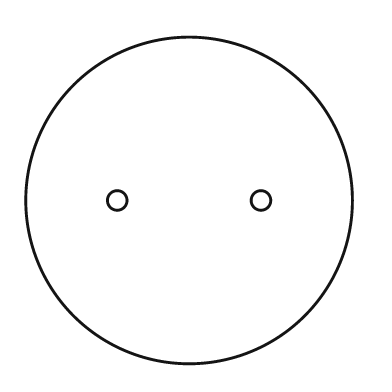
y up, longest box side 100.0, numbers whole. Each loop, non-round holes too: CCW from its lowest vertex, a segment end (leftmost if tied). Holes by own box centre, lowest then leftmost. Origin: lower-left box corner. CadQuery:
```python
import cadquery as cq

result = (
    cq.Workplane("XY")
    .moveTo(50.0, 50.0)
    .circle(50.0)
    .moveTo(28.0, 50.0)
    .circle(3.0)
    .moveTo(72.0, 50.0)
    .circle(3.0)
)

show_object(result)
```